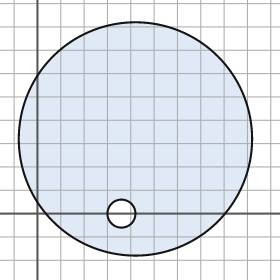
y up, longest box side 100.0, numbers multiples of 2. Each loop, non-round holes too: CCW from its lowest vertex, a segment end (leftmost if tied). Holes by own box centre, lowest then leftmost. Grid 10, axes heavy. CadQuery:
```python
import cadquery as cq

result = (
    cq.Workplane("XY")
    .moveTo(42.0, 32.0)
    .circle(50.0)
    .moveTo(36.0, 0.0)
    .circle(6.0)
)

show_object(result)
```